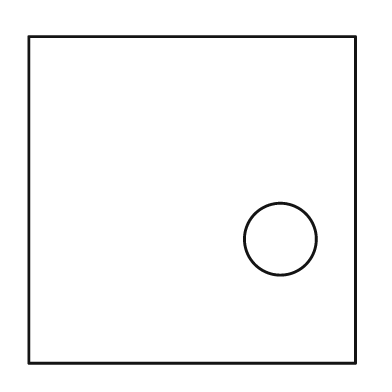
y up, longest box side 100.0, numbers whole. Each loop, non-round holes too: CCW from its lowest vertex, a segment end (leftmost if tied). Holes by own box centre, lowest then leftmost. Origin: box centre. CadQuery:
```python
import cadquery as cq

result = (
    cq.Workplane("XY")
    .moveTo(-50.0, -50.0)
    .lineTo(50.0, -50.0)
    .lineTo(50.0, 50.0)
    .lineTo(-50.0, 50.0)
    .close()
    .moveTo(27.0, -12.0)
    .circle(11.0)
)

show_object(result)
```